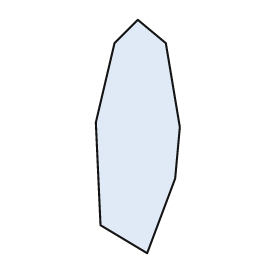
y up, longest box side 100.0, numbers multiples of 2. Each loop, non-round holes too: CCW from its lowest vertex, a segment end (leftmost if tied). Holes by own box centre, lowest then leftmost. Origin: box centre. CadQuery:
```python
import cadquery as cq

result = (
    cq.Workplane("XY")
    .moveTo(4.0, -50.0)
    .lineTo(16.0, -18.0)
    .lineTo(18.0, 4.0)
    .lineTo(12.0, 40.0)
    .lineTo(0.0, 50.0)
    .lineTo(-10.0, 40.0)
    .lineTo(-18.0, 6.0)
    .lineTo(-16.0, -38.0)
    .close()
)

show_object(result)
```